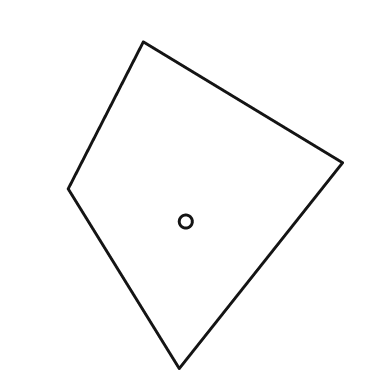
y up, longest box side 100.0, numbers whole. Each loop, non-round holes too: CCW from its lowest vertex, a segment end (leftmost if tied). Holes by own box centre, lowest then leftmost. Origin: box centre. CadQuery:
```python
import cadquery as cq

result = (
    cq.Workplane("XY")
    .moveTo(-8.0, -50.0)
    .lineTo(42.0, 13.0)
    .lineTo(-19.0, 50.0)
    .lineTo(-42.0, 5.0)
    .close()
    .moveTo(-6.0, -5.0)
    .circle(2.0)
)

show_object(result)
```